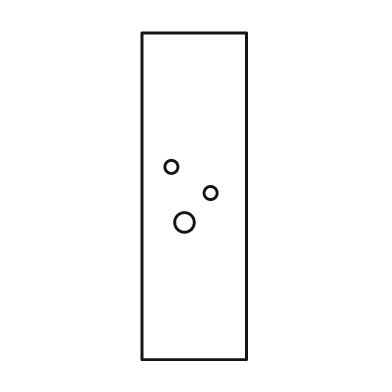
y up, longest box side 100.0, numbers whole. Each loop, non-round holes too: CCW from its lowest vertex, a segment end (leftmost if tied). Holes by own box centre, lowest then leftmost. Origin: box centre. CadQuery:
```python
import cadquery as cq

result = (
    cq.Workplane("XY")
    .moveTo(-16.0, -50.0)
    .lineTo(16.0, -50.0)
    .lineTo(16.0, 50.0)
    .lineTo(-16.0, 50.0)
    .close()
    .moveTo(-3.0, -8.0)
    .circle(3.0)
    .moveTo(5.0, 1.0)
    .circle(2.0)
    .moveTo(-7.0, 9.0)
    .circle(2.0)
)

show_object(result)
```